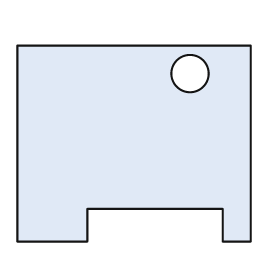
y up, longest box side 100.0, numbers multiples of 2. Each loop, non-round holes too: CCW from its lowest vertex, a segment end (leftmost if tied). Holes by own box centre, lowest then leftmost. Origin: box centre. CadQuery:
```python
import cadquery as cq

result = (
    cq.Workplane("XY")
    .moveTo(-50.0, -42.0)
    .lineTo(-20.0, -42.0)
    .lineTo(-20.0, -28.0)
    .lineTo(38.0, -28.0)
    .lineTo(38.0, -42.0)
    .lineTo(50.0, -42.0)
    .lineTo(50.0, 42.0)
    .lineTo(-50.0, 42.0)
    .close()
    .moveTo(24.0, 30.0)
    .circle(8.0)
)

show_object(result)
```